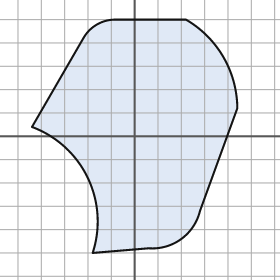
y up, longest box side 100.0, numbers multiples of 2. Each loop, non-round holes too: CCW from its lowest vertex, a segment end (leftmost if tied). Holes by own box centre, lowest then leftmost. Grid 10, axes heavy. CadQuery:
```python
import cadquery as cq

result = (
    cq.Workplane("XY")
    .moveTo(-18.0, -50.0)
    .lineTo(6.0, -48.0)
    .threePointArc((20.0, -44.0), (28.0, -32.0))
    .lineTo(44.0, 12.0)
    .threePointArc((38.0, 34.0), (22.0, 50.0))
    .lineTo(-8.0, 50.0)
    .threePointArc((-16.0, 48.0), (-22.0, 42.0))
    .lineTo(-44.0, 4.0)
    .threePointArc((-20.0, -18.0), (-18.0, -50.0))
    .close()
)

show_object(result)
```